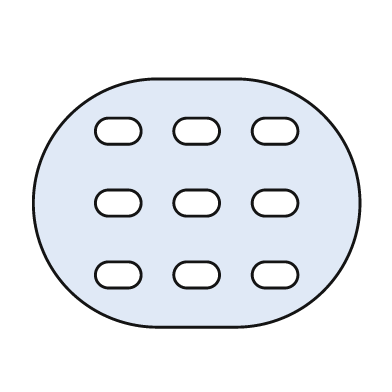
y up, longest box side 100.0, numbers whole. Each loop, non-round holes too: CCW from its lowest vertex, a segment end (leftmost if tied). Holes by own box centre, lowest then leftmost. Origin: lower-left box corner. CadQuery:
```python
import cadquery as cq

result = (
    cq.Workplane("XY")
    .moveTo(38.0, 0.0)
    .lineTo(62.0, 0.0)
    .threePointArc((100.0, 38.0), (62.0, 76.0))
    .lineTo(38.0, 76.0)
    .threePointArc((0.0, 38.0), (38.0, 0.0))
    .close()
    .moveTo(23.0, 12.0)
    .lineTo(29.0, 12.0)
    .threePointArc((33.0, 16.0), (29.0, 20.0))
    .lineTo(23.0, 20.0)
    .threePointArc((19.0, 16.0), (23.0, 12.0))
    .close()
    .moveTo(47.0, 12.0)
    .lineTo(53.0, 12.0)
    .threePointArc((57.0, 16.0), (53.0, 20.0))
    .lineTo(47.0, 20.0)
    .threePointArc((43.0, 16.0), (47.0, 12.0))
    .close()
    .moveTo(71.0, 12.0)
    .lineTo(77.0, 12.0)
    .threePointArc((81.0, 16.0), (77.0, 20.0))
    .lineTo(71.0, 20.0)
    .threePointArc((67.0, 16.0), (71.0, 12.0))
    .close()
    .moveTo(23.0, 34.0)
    .lineTo(29.0, 34.0)
    .threePointArc((33.0, 38.0), (29.0, 42.0))
    .lineTo(23.0, 42.0)
    .threePointArc((19.0, 38.0), (23.0, 34.0))
    .close()
    .moveTo(47.0, 34.0)
    .lineTo(53.0, 34.0)
    .threePointArc((57.0, 38.0), (53.0, 42.0))
    .lineTo(47.0, 42.0)
    .threePointArc((43.0, 38.0), (47.0, 34.0))
    .close()
    .moveTo(71.0, 34.0)
    .lineTo(77.0, 34.0)
    .threePointArc((81.0, 38.0), (77.0, 42.0))
    .lineTo(71.0, 42.0)
    .threePointArc((67.0, 38.0), (71.0, 34.0))
    .close()
    .moveTo(23.0, 56.0)
    .lineTo(29.0, 56.0)
    .threePointArc((33.0, 60.0), (29.0, 64.0))
    .lineTo(23.0, 64.0)
    .threePointArc((19.0, 60.0), (23.0, 56.0))
    .close()
    .moveTo(47.0, 56.0)
    .lineTo(53.0, 56.0)
    .threePointArc((57.0, 60.0), (53.0, 64.0))
    .lineTo(47.0, 64.0)
    .threePointArc((43.0, 60.0), (47.0, 56.0))
    .close()
    .moveTo(71.0, 56.0)
    .lineTo(77.0, 56.0)
    .threePointArc((81.0, 60.0), (77.0, 64.0))
    .lineTo(71.0, 64.0)
    .threePointArc((67.0, 60.0), (71.0, 56.0))
    .close()
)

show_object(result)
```